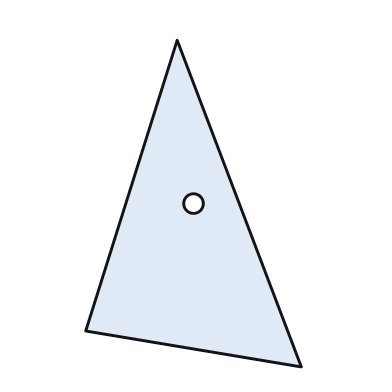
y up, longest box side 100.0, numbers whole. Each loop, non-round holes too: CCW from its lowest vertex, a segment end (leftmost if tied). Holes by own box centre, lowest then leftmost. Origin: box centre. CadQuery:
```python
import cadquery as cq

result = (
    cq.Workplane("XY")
    .moveTo(33.0, -50.0)
    .lineTo(-5.0, 50.0)
    .lineTo(-33.0, -39.0)
    .close()
    .moveTo(0.0, 0.0)
    .circle(3.0)
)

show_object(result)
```